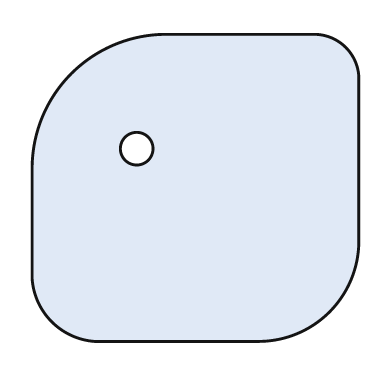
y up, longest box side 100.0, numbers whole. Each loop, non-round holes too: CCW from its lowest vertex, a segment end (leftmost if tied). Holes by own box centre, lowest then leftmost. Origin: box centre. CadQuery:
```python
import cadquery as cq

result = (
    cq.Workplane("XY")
    .moveTo(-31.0, -47.0)
    .lineTo(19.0, -47.0)
    .threePointArc((41.0, -38.0), (50.0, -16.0))
    .lineTo(50.0, 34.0)
    .threePointArc((46.0, 43.0), (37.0, 47.0))
    .lineTo(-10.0, 47.0)
    .threePointArc((-38.0, 35.0), (-50.0, 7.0))
    .lineTo(-50.0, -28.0)
    .threePointArc((-44.0, -41.0), (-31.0, -47.0))
    .close()
    .moveTo(-18.0, 12.0)
    .circle(5.0)
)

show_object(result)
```